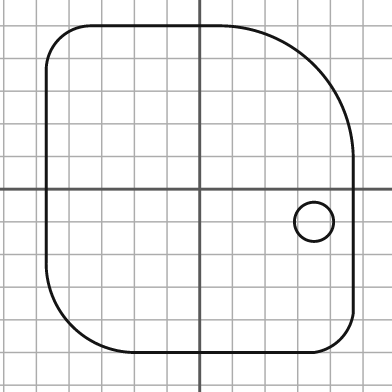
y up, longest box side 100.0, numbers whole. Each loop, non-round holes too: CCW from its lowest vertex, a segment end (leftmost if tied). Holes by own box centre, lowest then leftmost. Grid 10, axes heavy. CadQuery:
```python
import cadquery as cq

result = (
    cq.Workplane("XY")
    .moveTo(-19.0, -50.0)
    .lineTo(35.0, -50.0)
    .threePointArc((43.0, -46.0), (47.0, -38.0))
    .lineTo(47.0, 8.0)
    .threePointArc((35.0, 38.0), (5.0, 50.0))
    .lineTo(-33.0, 50.0)
    .threePointArc((-43.0, 46.0), (-47.0, 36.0))
    .lineTo(-47.0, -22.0)
    .threePointArc((-39.0, -42.0), (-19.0, -50.0))
    .close()
    .moveTo(35.0, -10.0)
    .circle(6.0)
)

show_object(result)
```